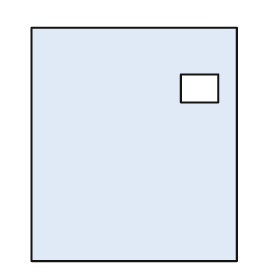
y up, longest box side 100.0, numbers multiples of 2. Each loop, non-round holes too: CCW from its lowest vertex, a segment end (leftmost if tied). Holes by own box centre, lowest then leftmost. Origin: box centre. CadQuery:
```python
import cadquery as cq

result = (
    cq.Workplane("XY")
    .moveTo(-44.0, -50.0)
    .lineTo(44.0, -50.0)
    .lineTo(44.0, 50.0)
    .lineTo(-44.0, 50.0)
    .close()
    .moveTo(20.0, 18.0)
    .lineTo(36.0, 18.0)
    .lineTo(36.0, 30.0)
    .lineTo(20.0, 30.0)
    .close()
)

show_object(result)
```